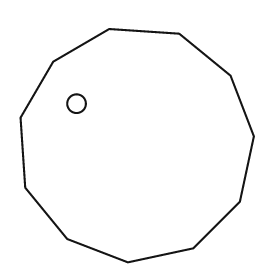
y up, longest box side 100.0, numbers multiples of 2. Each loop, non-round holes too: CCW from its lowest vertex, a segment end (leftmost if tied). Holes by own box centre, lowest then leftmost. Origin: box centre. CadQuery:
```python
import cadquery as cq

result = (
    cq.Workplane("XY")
    .moveTo(-4.0, -50.0)
    .lineTo(24.0, -44.0)
    .lineTo(44.0, -24.0)
    .lineTo(50.0, 4.0)
    .lineTo(40.0, 30.0)
    .lineTo(18.0, 48.0)
    .lineTo(-12.0, 50.0)
    .lineTo(-36.0, 36.0)
    .lineTo(-50.0, 12.0)
    .lineTo(-48.0, -18.0)
    .lineTo(-30.0, -40.0)
    .close()
    .moveTo(-26.0, 18.0)
    .circle(4.0)
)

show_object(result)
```